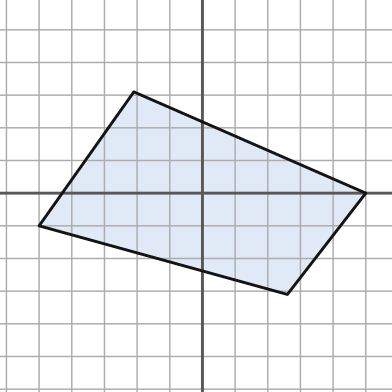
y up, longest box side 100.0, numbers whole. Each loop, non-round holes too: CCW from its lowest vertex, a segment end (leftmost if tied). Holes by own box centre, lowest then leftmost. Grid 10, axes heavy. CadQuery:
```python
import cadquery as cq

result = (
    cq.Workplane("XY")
    .moveTo(26.0, -31.0)
    .lineTo(50.0, 0.0)
    .lineTo(-21.0, 31.0)
    .lineTo(-50.0, -10.0)
    .close()
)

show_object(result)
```